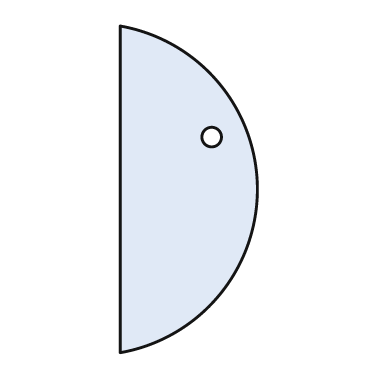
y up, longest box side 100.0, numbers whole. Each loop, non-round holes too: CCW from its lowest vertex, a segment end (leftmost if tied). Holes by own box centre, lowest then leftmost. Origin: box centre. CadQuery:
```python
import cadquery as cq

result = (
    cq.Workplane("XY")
    .moveTo(-21.0, -50.0)
    .threePointArc((21.0, 0.0), (-21.0, 50.0))
    .close()
    .moveTo(7.0, 16.0)
    .circle(3.0)
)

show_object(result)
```